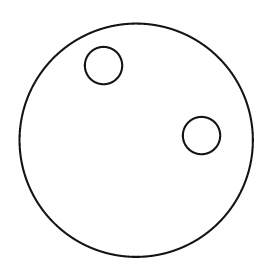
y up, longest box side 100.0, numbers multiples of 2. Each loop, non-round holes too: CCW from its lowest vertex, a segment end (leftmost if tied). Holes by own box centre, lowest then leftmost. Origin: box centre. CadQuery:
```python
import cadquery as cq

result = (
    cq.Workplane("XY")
    .moveTo(0.0, 0.0)
    .circle(50.0)
    .moveTo(28.0, 2.0)
    .circle(8.0)
    .moveTo(-14.0, 32.0)
    .circle(8.0)
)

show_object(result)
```